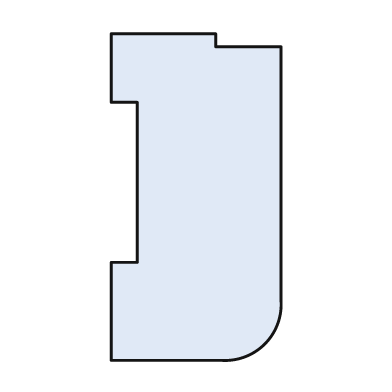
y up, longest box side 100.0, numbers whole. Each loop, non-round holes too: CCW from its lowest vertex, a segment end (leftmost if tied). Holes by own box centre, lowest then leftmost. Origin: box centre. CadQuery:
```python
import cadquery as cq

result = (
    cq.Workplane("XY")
    .moveTo(-26.0, -50.0)
    .lineTo(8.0, -50.0)
    .threePointArc((21.0, -45.0), (26.0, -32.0))
    .lineTo(26.0, 46.0)
    .lineTo(6.0, 46.0)
    .lineTo(6.0, 50.0)
    .lineTo(-26.0, 50.0)
    .lineTo(-26.0, 29.0)
    .lineTo(-18.0, 29.0)
    .lineTo(-18.0, -20.0)
    .lineTo(-26.0, -20.0)
    .close()
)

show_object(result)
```